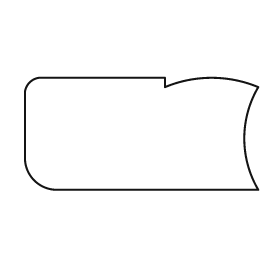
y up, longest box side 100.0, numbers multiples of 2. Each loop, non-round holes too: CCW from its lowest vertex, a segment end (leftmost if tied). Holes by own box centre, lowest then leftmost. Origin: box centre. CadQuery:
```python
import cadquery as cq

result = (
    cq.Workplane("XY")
    .moveTo(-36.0, -24.0)
    .lineTo(50.0, -24.0)
    .threePointArc((44.0, -2.0), (50.0, 20.0))
    .threePointArc((30.0, 24.0), (10.0, 20.0))
    .lineTo(10.0, 24.0)
    .lineTo(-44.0, 24.0)
    .threePointArc((-48.0, 22.0), (-50.0, 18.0))
    .lineTo(-50.0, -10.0)
    .threePointArc((-46.0, -20.0), (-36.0, -24.0))
    .close()
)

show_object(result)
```